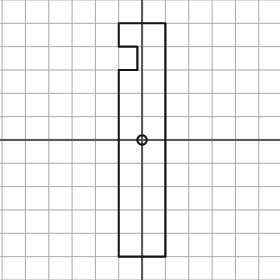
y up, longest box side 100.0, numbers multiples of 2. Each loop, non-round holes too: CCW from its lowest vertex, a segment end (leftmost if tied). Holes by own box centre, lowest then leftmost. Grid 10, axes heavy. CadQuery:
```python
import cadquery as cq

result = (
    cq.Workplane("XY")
    .moveTo(-10.0, -50.0)
    .lineTo(10.0, -50.0)
    .lineTo(10.0, 50.0)
    .lineTo(-10.0, 50.0)
    .lineTo(-10.0, 40.0)
    .lineTo(-2.0, 40.0)
    .lineTo(-2.0, 30.0)
    .lineTo(-10.0, 30.0)
    .close()
    .moveTo(0.0, 0.0)
    .circle(2.0)
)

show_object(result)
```